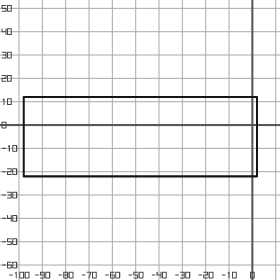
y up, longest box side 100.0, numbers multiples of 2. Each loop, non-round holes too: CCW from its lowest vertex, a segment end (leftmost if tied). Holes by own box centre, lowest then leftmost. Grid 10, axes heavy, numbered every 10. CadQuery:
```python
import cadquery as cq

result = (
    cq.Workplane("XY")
    .moveTo(-98.0, -22.0)
    .lineTo(2.0, -22.0)
    .lineTo(2.0, 12.0)
    .lineTo(-98.0, 12.0)
    .close()
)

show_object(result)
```